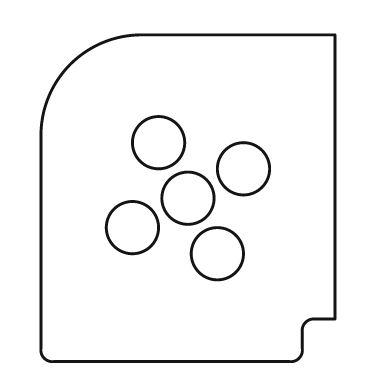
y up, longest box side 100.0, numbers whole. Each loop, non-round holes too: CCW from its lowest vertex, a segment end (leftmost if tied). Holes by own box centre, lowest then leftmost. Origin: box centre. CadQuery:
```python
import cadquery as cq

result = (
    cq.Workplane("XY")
    .moveTo(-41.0, -50.0)
    .lineTo(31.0, -50.0)
    .threePointArc((34.0, -49.0), (35.0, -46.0))
    .lineTo(35.0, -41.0)
    .threePointArc((36.0, -38.0), (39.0, -37.0))
    .lineTo(45.0, -37.0)
    .lineTo(45.0, 50.0)
    .lineTo(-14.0, 50.0)
    .threePointArc((-36.0, 41.0), (-45.0, 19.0))
    .lineTo(-45.0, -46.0)
    .threePointArc((-44.0, -49.0), (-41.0, -50.0))
    .close()
    .moveTo(9.0, -17.0)
    .circle(8.0)
    .moveTo(-17.0, -9.0)
    .circle(8.0)
    .moveTo(0.0, 0.0)
    .circle(8.0)
    .moveTo(17.0, 9.0)
    .circle(8.0)
    .moveTo(-9.0, 17.0)
    .circle(8.0)
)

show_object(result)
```